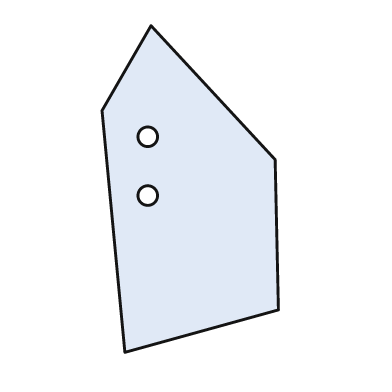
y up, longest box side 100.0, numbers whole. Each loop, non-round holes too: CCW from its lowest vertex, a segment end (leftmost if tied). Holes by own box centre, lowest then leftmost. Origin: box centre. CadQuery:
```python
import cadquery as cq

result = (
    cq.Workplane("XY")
    .moveTo(-20.0, -50.0)
    .lineTo(27.0, -37.0)
    .lineTo(26.0, 9.0)
    .lineTo(-12.0, 50.0)
    .lineTo(-27.0, 24.0)
    .close()
    .moveTo(-13.0, -2.0)
    .circle(3.0)
    .moveTo(-13.0, 16.0)
    .circle(3.0)
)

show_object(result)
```